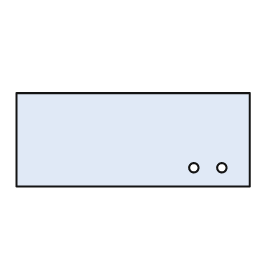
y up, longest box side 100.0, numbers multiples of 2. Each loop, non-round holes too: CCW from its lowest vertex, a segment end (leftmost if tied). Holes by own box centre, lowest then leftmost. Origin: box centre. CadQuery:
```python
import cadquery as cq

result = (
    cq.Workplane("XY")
    .moveTo(-50.0, -20.0)
    .lineTo(50.0, -20.0)
    .lineTo(50.0, 20.0)
    .lineTo(-50.0, 20.0)
    .close()
    .moveTo(26.0, -12.0)
    .circle(2.0)
    .moveTo(38.0, -12.0)
    .circle(2.0)
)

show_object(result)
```